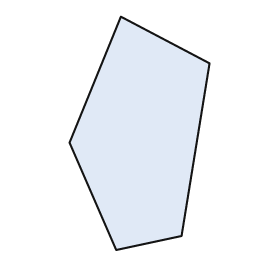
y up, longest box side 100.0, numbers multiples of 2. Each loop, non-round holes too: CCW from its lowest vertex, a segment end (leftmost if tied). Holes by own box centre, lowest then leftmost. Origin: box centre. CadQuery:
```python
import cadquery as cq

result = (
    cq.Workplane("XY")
    .moveTo(-10.0, -50.0)
    .lineTo(18.0, -44.0)
    .lineTo(30.0, 30.0)
    .lineTo(-8.0, 50.0)
    .lineTo(-30.0, -4.0)
    .close()
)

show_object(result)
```